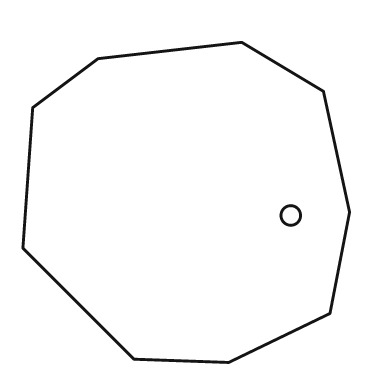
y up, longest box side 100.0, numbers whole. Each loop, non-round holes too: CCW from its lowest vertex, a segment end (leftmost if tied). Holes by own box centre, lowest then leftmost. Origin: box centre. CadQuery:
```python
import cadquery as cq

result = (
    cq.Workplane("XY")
    .moveTo(13.0, -49.0)
    .lineTo(44.0, -34.0)
    .lineTo(50.0, -3.0)
    .lineTo(42.0, 34.0)
    .lineTo(17.0, 49.0)
    .lineTo(-27.0, 44.0)
    .lineTo(-47.0, 29.0)
    .lineTo(-50.0, -14.0)
    .lineTo(-16.0, -48.0)
    .close()
    .moveTo(32.0, -4.0)
    .circle(3.0)
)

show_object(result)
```